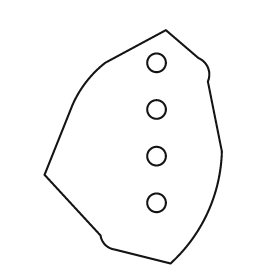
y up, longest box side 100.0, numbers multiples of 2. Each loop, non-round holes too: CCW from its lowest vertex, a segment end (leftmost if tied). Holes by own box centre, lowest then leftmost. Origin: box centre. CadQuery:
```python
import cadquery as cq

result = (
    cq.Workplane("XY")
    .moveTo(16.0, -50.0)
    .threePointArc((32.0, -28.0), (38.0, -2.0))
    .lineTo(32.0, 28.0)
    .threePointArc((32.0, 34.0), (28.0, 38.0))
    .lineTo(14.0, 50.0)
    .lineTo(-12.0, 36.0)
    .threePointArc((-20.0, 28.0), (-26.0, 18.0))
    .lineTo(-38.0, -12.0)
    .lineTo(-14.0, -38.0)
    .threePointArc((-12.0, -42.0), (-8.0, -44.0))
    .close()
    .moveTo(10.0, -24.0)
    .circle(4.0)
    .moveTo(10.0, -4.0)
    .circle(4.0)
    .moveTo(10.0, 16.0)
    .circle(4.0)
    .moveTo(10.0, 36.0)
    .circle(4.0)
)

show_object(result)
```